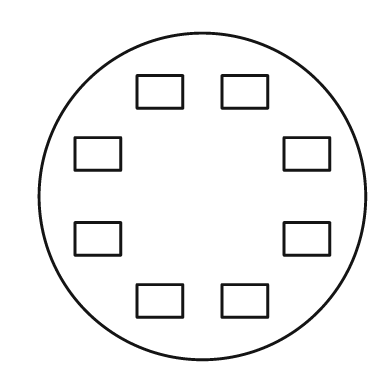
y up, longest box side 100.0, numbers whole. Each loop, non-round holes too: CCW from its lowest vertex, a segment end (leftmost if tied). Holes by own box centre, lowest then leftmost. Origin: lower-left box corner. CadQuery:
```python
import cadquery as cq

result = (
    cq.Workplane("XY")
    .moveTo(50.0, 50.0)
    .circle(50.0)
    .moveTo(30.0, 13.0)
    .lineTo(44.0, 13.0)
    .lineTo(44.0, 23.0)
    .lineTo(30.0, 23.0)
    .close()
    .moveTo(56.0, 13.0)
    .lineTo(70.0, 13.0)
    .lineTo(70.0, 23.0)
    .lineTo(56.0, 23.0)
    .close()
    .moveTo(11.0, 32.0)
    .lineTo(25.0, 32.0)
    .lineTo(25.0, 42.0)
    .lineTo(11.0, 42.0)
    .close()
    .moveTo(75.0, 32.0)
    .lineTo(89.0, 32.0)
    .lineTo(89.0, 42.0)
    .lineTo(75.0, 42.0)
    .close()
    .moveTo(11.0, 58.0)
    .lineTo(25.0, 58.0)
    .lineTo(25.0, 68.0)
    .lineTo(11.0, 68.0)
    .close()
    .moveTo(75.0, 58.0)
    .lineTo(89.0, 58.0)
    .lineTo(89.0, 68.0)
    .lineTo(75.0, 68.0)
    .close()
    .moveTo(30.0, 77.0)
    .lineTo(44.0, 77.0)
    .lineTo(44.0, 87.0)
    .lineTo(30.0, 87.0)
    .close()
    .moveTo(56.0, 77.0)
    .lineTo(70.0, 77.0)
    .lineTo(70.0, 87.0)
    .lineTo(56.0, 87.0)
    .close()
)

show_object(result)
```